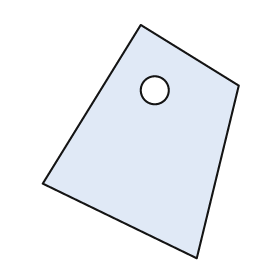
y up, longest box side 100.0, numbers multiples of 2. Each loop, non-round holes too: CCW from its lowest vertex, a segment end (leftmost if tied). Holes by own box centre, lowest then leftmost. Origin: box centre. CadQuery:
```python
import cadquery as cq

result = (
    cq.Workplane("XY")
    .moveTo(24.0, -50.0)
    .lineTo(42.0, 24.0)
    .lineTo(0.0, 50.0)
    .lineTo(-42.0, -18.0)
    .close()
    .moveTo(6.0, 22.0)
    .circle(6.0)
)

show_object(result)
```